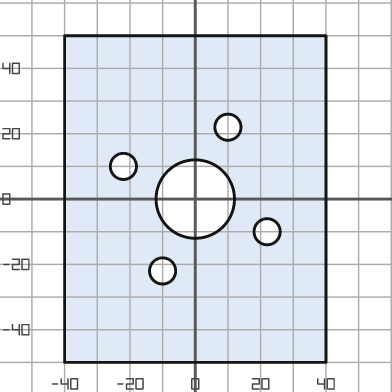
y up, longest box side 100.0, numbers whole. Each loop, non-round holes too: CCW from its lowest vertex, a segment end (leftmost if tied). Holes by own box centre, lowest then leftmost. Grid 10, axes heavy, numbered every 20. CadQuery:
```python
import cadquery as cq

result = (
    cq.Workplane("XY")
    .moveTo(-40.0, -50.0)
    .lineTo(40.0, -50.0)
    .lineTo(40.0, 50.0)
    .lineTo(-40.0, 50.0)
    .close()
    .moveTo(-10.0, -22.0)
    .circle(4.0)
    .moveTo(22.0, -10.0)
    .circle(4.0)
    .moveTo(0.0, 0.0)
    .circle(12.0)
    .moveTo(-22.0, 10.0)
    .circle(4.0)
    .moveTo(10.0, 22.0)
    .circle(4.0)
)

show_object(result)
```